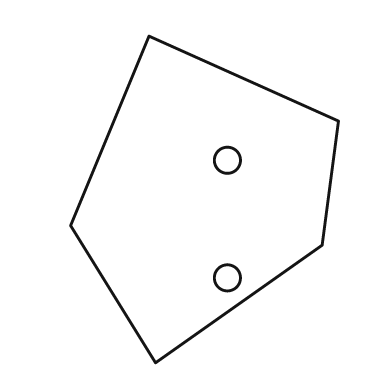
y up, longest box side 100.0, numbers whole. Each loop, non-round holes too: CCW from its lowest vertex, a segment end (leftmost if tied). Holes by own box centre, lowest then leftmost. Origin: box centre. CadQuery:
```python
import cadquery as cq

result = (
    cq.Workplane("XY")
    .moveTo(-15.0, -50.0)
    .lineTo(36.0, -14.0)
    .lineTo(41.0, 24.0)
    .lineTo(-17.0, 50.0)
    .lineTo(-41.0, -8.0)
    .close()
    .moveTo(7.0, -24.0)
    .circle(4.0)
    .moveTo(7.0, 12.0)
    .circle(4.0)
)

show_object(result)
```